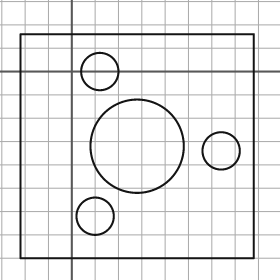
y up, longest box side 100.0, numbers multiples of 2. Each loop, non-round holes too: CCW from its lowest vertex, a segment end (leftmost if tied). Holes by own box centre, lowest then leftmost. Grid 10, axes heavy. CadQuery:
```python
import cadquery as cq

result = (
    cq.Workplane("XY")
    .moveTo(-22.0, -80.0)
    .lineTo(78.0, -80.0)
    .lineTo(78.0, 16.0)
    .lineTo(-22.0, 16.0)
    .close()
    .moveTo(10.0, -62.0)
    .circle(8.0)
    .moveTo(64.0, -34.0)
    .circle(8.0)
    .moveTo(28.0, -32.0)
    .circle(20.0)
    .moveTo(12.0, 0.0)
    .circle(8.0)
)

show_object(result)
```